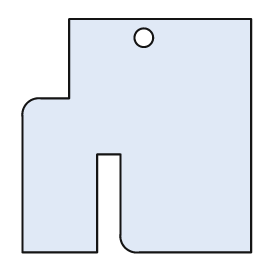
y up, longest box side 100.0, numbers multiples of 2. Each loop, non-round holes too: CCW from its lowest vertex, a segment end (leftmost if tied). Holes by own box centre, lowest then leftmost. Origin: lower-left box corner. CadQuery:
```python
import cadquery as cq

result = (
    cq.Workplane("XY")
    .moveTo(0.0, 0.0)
    .lineTo(32.0, 0.0)
    .lineTo(32.0, 42.0)
    .lineTo(42.0, 42.0)
    .lineTo(42.0, 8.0)
    .threePointArc((44.0, 2.0), (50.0, 0.0))
    .lineTo(98.0, 0.0)
    .lineTo(98.0, 100.0)
    .lineTo(20.0, 100.0)
    .lineTo(20.0, 66.0)
    .lineTo(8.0, 66.0)
    .threePointArc((2.0, 64.0), (0.0, 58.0))
    .close()
    .moveTo(52.0, 92.0)
    .circle(4.0)
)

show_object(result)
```